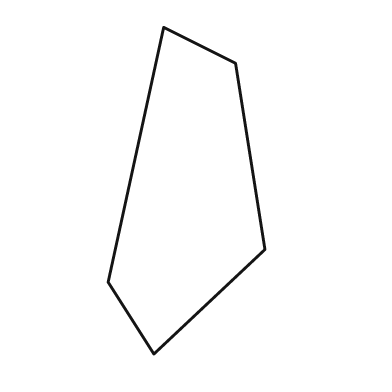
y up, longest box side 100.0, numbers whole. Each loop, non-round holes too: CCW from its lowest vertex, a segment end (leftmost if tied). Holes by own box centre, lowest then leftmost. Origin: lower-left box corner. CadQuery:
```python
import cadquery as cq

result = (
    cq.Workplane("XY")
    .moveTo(14.0, 0.0)
    .lineTo(48.0, 32.0)
    .lineTo(39.0, 89.0)
    .lineTo(17.0, 100.0)
    .lineTo(0.0, 22.0)
    .close()
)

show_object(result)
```